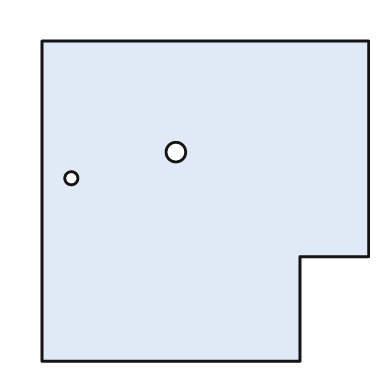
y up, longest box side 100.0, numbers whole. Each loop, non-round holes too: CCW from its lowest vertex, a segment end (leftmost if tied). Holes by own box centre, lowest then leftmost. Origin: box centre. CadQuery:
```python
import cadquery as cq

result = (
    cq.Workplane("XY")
    .moveTo(-50.0, -49.0)
    .lineTo(29.0, -49.0)
    .lineTo(29.0, -17.0)
    .lineTo(50.0, -17.0)
    .lineTo(50.0, 49.0)
    .lineTo(-50.0, 49.0)
    .close()
    .moveTo(-41.0, 7.0)
    .circle(2.0)
    .moveTo(-9.0, 15.0)
    .circle(3.0)
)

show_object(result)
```